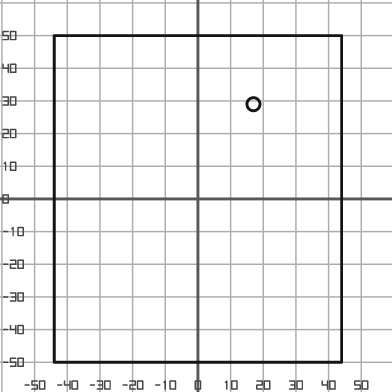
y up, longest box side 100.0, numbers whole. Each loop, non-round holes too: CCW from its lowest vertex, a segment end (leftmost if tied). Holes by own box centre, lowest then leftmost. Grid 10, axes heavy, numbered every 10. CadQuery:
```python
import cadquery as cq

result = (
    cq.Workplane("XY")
    .moveTo(-44.0, -50.0)
    .lineTo(44.0, -50.0)
    .lineTo(44.0, 50.0)
    .lineTo(-44.0, 50.0)
    .close()
    .moveTo(17.0, 29.0)
    .circle(2.0)
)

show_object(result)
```